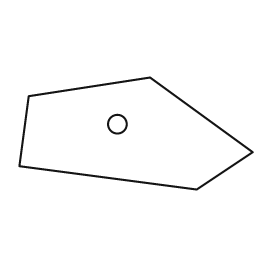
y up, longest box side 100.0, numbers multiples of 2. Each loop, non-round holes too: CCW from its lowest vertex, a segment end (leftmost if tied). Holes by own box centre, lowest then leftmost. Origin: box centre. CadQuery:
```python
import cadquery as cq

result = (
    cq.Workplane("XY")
    .moveTo(26.0, -24.0)
    .lineTo(50.0, -8.0)
    .lineTo(6.0, 24.0)
    .lineTo(-46.0, 16.0)
    .lineTo(-50.0, -14.0)
    .close()
    .moveTo(-8.0, 4.0)
    .circle(4.0)
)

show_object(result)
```